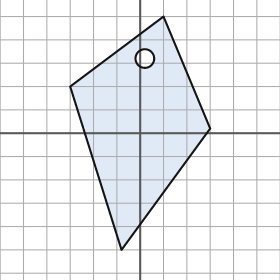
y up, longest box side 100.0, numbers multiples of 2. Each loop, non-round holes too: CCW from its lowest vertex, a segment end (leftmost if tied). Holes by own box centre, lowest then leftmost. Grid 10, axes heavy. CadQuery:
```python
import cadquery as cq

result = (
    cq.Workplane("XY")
    .moveTo(-8.0, -50.0)
    .lineTo(30.0, 2.0)
    .lineTo(10.0, 50.0)
    .lineTo(-30.0, 20.0)
    .close()
    .moveTo(2.0, 32.0)
    .circle(4.0)
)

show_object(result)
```